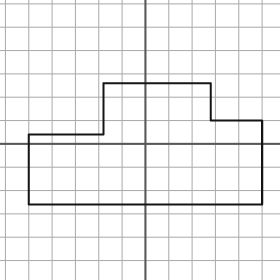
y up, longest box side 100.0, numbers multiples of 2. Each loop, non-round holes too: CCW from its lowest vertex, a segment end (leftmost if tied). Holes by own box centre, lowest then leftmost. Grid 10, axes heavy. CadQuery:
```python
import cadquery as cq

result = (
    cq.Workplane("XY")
    .moveTo(-50.0, -26.0)
    .lineTo(50.0, -26.0)
    .lineTo(50.0, 10.0)
    .lineTo(28.0, 10.0)
    .lineTo(28.0, 26.0)
    .lineTo(-18.0, 26.0)
    .lineTo(-18.0, 4.0)
    .lineTo(-50.0, 4.0)
    .close()
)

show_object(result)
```